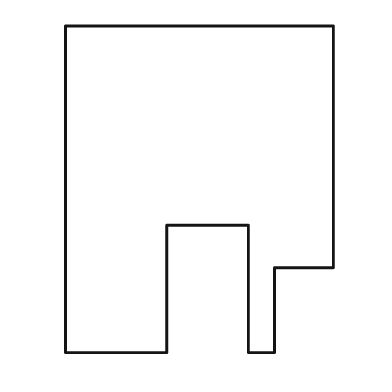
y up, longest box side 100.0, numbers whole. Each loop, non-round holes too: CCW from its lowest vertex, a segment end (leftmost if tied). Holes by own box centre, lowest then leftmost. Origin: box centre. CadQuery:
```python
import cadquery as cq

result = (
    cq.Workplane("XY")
    .moveTo(-41.0, -50.0)
    .lineTo(-10.0, -50.0)
    .lineTo(-10.0, -11.0)
    .lineTo(15.0, -11.0)
    .lineTo(15.0, -50.0)
    .lineTo(23.0, -50.0)
    .lineTo(23.0, -24.0)
    .lineTo(41.0, -24.0)
    .lineTo(41.0, 50.0)
    .lineTo(-41.0, 50.0)
    .close()
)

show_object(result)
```